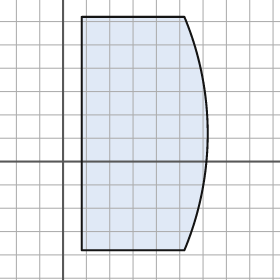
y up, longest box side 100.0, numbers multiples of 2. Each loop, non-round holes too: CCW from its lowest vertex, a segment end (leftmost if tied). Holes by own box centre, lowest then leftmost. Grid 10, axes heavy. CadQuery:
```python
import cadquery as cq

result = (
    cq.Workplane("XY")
    .moveTo(8.0, -38.0)
    .lineTo(52.0, -38.0)
    .threePointArc((62.0, 12.0), (52.0, 62.0))
    .lineTo(8.0, 62.0)
    .close()
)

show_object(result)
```